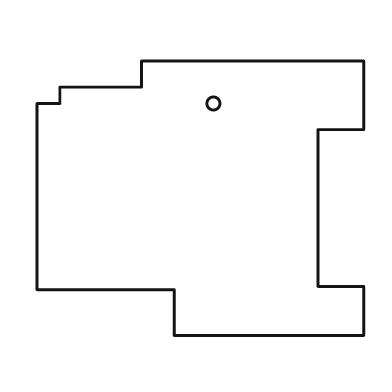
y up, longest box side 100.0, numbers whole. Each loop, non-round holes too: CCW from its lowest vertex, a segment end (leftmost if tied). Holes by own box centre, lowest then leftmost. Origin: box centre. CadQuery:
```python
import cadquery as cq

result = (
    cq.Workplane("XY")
    .moveTo(-8.0, -42.0)
    .lineTo(50.0, -42.0)
    .lineTo(50.0, -27.0)
    .lineTo(36.0, -27.0)
    .lineTo(36.0, 21.0)
    .lineTo(50.0, 21.0)
    .lineTo(50.0, 42.0)
    .lineTo(-18.0, 42.0)
    .lineTo(-18.0, 34.0)
    .lineTo(-43.0, 34.0)
    .lineTo(-43.0, 29.0)
    .lineTo(-50.0, 29.0)
    .lineTo(-50.0, -28.0)
    .lineTo(-8.0, -28.0)
    .close()
    .moveTo(4.0, 29.0)
    .circle(2.0)
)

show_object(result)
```